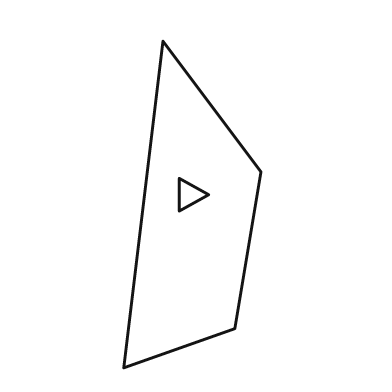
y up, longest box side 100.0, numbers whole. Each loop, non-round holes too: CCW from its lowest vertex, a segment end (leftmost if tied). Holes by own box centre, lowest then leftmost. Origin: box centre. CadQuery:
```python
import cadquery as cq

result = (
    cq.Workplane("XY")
    .moveTo(-21.0, -50.0)
    .lineTo(13.0, -38.0)
    .lineTo(21.0, 10.0)
    .lineTo(-9.0, 50.0)
    .close()
    .moveTo(-4.0, -2.0)
    .lineTo(5.0, 3.0)
    .lineTo(-4.0, 8.0)
    .close()
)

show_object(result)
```